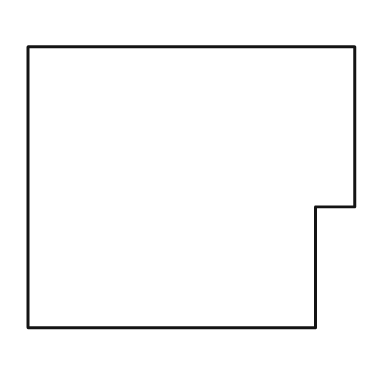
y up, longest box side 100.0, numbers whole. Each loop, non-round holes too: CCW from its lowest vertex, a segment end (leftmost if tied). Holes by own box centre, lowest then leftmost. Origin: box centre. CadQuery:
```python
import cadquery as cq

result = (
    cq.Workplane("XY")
    .moveTo(-50.0, -43.0)
    .lineTo(38.0, -43.0)
    .lineTo(38.0, -6.0)
    .lineTo(50.0, -6.0)
    .lineTo(50.0, 43.0)
    .lineTo(-50.0, 43.0)
    .close()
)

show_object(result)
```